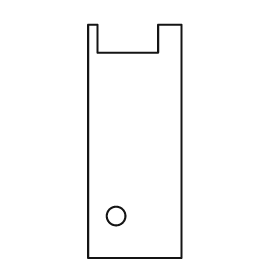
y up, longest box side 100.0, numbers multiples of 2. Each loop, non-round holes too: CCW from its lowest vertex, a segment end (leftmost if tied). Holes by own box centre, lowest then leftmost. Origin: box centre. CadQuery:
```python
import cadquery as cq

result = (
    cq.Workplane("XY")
    .moveTo(-20.0, -50.0)
    .lineTo(20.0, -50.0)
    .lineTo(20.0, 50.0)
    .lineTo(10.0, 50.0)
    .lineTo(10.0, 38.0)
    .lineTo(-16.0, 38.0)
    .lineTo(-16.0, 50.0)
    .lineTo(-20.0, 50.0)
    .close()
    .moveTo(-8.0, -32.0)
    .circle(4.0)
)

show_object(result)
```